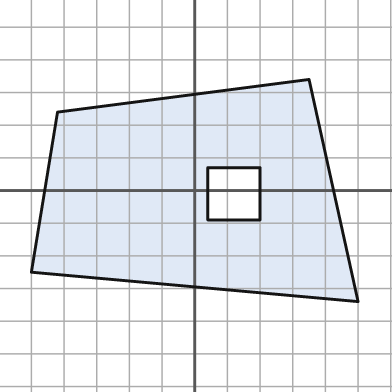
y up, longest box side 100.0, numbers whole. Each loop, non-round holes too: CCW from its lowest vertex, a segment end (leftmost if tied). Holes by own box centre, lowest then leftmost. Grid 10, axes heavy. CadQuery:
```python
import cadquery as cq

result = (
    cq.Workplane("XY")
    .moveTo(50.0, -34.0)
    .lineTo(35.0, 34.0)
    .lineTo(-42.0, 24.0)
    .lineTo(-50.0, -25.0)
    .close()
    .moveTo(4.0, -9.0)
    .lineTo(20.0, -9.0)
    .lineTo(20.0, 7.0)
    .lineTo(4.0, 7.0)
    .close()
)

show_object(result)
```